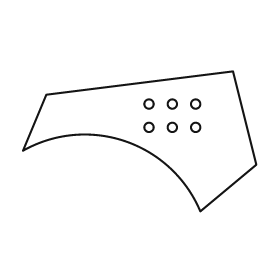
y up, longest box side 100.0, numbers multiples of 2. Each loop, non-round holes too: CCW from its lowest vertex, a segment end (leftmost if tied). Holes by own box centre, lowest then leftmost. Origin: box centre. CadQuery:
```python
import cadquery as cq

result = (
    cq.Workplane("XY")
    .moveTo(26.0, -30.0)
    .lineTo(50.0, -10.0)
    .lineTo(40.0, 30.0)
    .lineTo(-40.0, 20.0)
    .lineTo(-50.0, -4.0)
    .threePointArc((-6.0, 0.0), (26.0, -30.0))
    .close()
    .moveTo(4.0, 6.0)
    .circle(2.0)
    .moveTo(14.0, 6.0)
    .circle(2.0)
    .moveTo(24.0, 6.0)
    .circle(2.0)
    .moveTo(4.0, 16.0)
    .circle(2.0)
    .moveTo(14.0, 16.0)
    .circle(2.0)
    .moveTo(24.0, 16.0)
    .circle(2.0)
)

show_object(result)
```